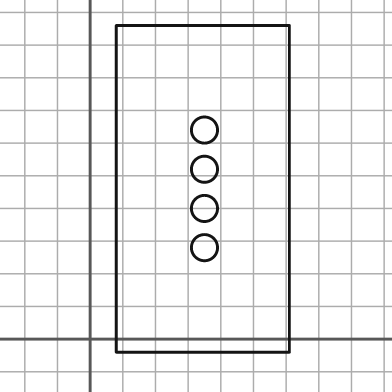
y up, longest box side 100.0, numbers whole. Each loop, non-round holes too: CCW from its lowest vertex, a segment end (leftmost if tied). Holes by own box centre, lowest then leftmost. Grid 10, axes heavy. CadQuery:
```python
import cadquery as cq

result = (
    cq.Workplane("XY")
    .moveTo(8.0, -4.0)
    .lineTo(61.0, -4.0)
    .lineTo(61.0, 96.0)
    .lineTo(8.0, 96.0)
    .close()
    .moveTo(35.0, 28.0)
    .circle(4.0)
    .moveTo(35.0, 40.0)
    .circle(4.0)
    .moveTo(35.0, 52.0)
    .circle(4.0)
    .moveTo(35.0, 64.0)
    .circle(4.0)
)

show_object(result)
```